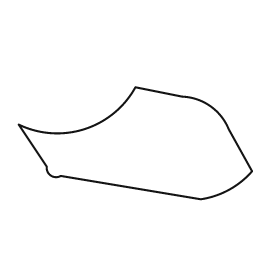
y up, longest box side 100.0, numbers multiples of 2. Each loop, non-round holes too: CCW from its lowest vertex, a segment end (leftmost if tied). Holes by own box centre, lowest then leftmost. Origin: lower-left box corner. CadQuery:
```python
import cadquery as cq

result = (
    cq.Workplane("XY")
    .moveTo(78.0, 0.0)
    .threePointArc((90.0, 4.0), (100.0, 12.0))
    .lineTo(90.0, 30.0)
    .threePointArc((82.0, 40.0), (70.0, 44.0))
    .lineTo(50.0, 48.0)
    .threePointArc((28.0, 30.0), (0.0, 32.0))
    .lineTo(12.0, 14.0)
    .threePointArc((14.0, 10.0), (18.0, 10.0))
    .close()
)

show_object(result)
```